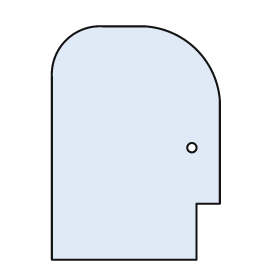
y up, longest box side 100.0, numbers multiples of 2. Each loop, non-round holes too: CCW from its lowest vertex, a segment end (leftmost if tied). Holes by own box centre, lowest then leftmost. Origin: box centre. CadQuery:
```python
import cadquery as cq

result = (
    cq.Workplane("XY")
    .moveTo(-36.0, -50.0)
    .lineTo(26.0, -50.0)
    .lineTo(26.0, -26.0)
    .lineTo(36.0, -26.0)
    .lineTo(36.0, 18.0)
    .threePointArc((26.0, 40.0), (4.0, 50.0))
    .lineTo(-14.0, 50.0)
    .threePointArc((-30.0, 44.0), (-36.0, 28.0))
    .close()
    .moveTo(24.0, -2.0)
    .circle(2.0)
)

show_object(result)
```